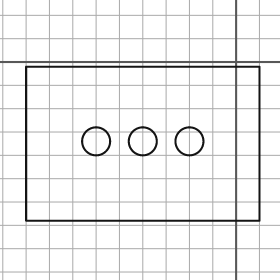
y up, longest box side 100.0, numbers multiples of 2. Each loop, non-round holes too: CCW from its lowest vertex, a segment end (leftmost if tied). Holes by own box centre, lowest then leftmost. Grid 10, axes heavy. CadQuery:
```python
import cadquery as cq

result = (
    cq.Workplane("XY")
    .moveTo(-90.0, -68.0)
    .lineTo(10.0, -68.0)
    .lineTo(10.0, -2.0)
    .lineTo(-90.0, -2.0)
    .close()
    .moveTo(-60.0, -34.0)
    .circle(6.0)
    .moveTo(-40.0, -34.0)
    .circle(6.0)
    .moveTo(-20.0, -34.0)
    .circle(6.0)
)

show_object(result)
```